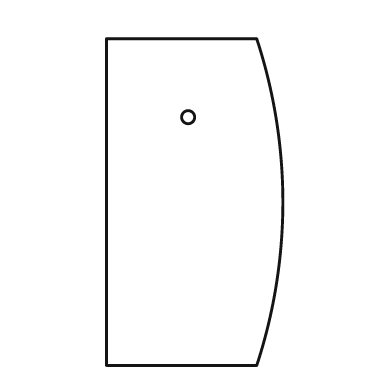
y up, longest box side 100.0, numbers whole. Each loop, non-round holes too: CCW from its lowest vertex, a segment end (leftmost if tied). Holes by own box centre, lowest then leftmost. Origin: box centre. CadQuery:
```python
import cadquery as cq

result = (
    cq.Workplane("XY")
    .moveTo(-27.0, -50.0)
    .lineTo(19.0, -50.0)
    .threePointArc((27.0, 0.0), (19.0, 50.0))
    .lineTo(-27.0, 50.0)
    .close()
    .moveTo(-2.0, 26.0)
    .circle(2.0)
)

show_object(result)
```